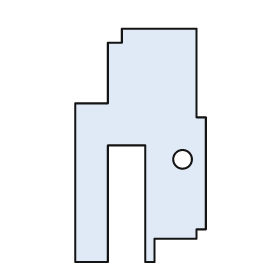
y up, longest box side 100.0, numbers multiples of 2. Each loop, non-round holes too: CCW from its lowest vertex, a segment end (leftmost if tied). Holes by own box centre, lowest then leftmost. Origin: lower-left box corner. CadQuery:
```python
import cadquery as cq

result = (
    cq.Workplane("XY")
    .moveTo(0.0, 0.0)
    .lineTo(14.0, 0.0)
    .lineTo(14.0, 50.0)
    .lineTo(30.0, 50.0)
    .lineTo(30.0, 0.0)
    .lineTo(34.0, 0.0)
    .lineTo(34.0, 10.0)
    .lineTo(52.0, 10.0)
    .lineTo(52.0, 14.0)
    .lineTo(56.0, 14.0)
    .lineTo(56.0, 62.0)
    .lineTo(52.0, 62.0)
    .lineTo(52.0, 100.0)
    .lineTo(20.0, 100.0)
    .lineTo(20.0, 94.0)
    .lineTo(14.0, 94.0)
    .lineTo(14.0, 68.0)
    .lineTo(0.0, 68.0)
    .close()
    .moveTo(46.0, 44.0)
    .circle(4.0)
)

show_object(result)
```